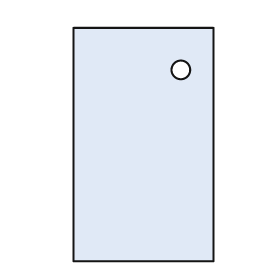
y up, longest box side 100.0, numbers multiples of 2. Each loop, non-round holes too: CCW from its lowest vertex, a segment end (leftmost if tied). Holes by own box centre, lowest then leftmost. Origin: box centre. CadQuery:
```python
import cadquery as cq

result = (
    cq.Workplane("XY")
    .moveTo(-30.0, -50.0)
    .lineTo(30.0, -50.0)
    .lineTo(30.0, 50.0)
    .lineTo(-30.0, 50.0)
    .close()
    .moveTo(16.0, 32.0)
    .circle(4.0)
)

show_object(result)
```